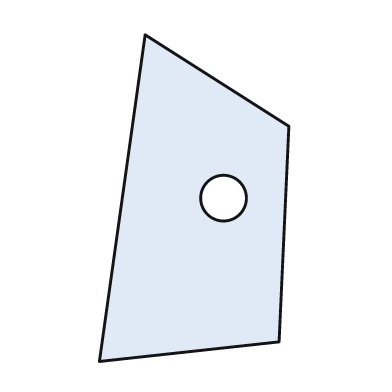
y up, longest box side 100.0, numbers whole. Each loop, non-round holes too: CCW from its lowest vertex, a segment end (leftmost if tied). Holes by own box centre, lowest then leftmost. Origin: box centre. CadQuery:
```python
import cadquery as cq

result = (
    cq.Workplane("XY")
    .moveTo(-29.0, -50.0)
    .lineTo(26.0, -44.0)
    .lineTo(29.0, 22.0)
    .lineTo(-15.0, 50.0)
    .close()
    .moveTo(9.0, 0.0)
    .circle(7.0)
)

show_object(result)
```